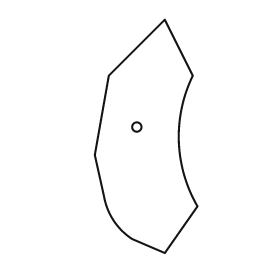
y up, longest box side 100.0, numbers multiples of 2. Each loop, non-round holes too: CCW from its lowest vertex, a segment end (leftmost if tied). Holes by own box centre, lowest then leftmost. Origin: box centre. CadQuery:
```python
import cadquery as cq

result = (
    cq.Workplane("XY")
    .moveTo(8.0, -50.0)
    .lineTo(22.0, -30.0)
    .threePointArc((14.0, -2.0), (20.0, 26.0))
    .lineTo(8.0, 50.0)
    .lineTo(-16.0, 26.0)
    .lineTo(-22.0, -8.0)
    .lineTo(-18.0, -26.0)
    .threePointArc((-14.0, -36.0), (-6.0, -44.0))
    .close()
    .moveTo(-4.0, 4.0)
    .circle(2.0)
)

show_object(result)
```